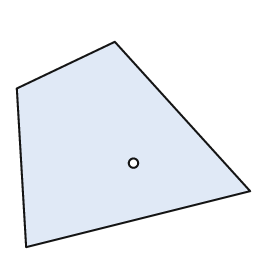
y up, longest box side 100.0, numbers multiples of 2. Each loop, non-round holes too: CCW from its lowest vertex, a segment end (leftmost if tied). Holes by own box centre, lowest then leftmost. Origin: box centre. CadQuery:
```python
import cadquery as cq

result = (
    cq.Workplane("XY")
    .moveTo(-46.0, -44.0)
    .lineTo(50.0, -20.0)
    .lineTo(-8.0, 44.0)
    .lineTo(-50.0, 24.0)
    .close()
    .moveTo(0.0, -8.0)
    .circle(2.0)
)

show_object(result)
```